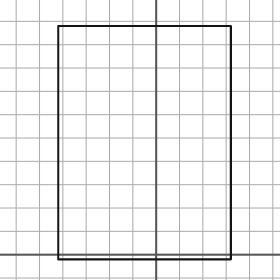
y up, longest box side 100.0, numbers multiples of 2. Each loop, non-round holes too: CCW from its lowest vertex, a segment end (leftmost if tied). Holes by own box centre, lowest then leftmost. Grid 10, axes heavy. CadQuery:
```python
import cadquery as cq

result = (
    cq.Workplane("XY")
    .moveTo(-42.0, -2.0)
    .lineTo(32.0, -2.0)
    .lineTo(32.0, 98.0)
    .lineTo(-42.0, 98.0)
    .close()
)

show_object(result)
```